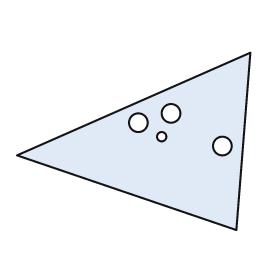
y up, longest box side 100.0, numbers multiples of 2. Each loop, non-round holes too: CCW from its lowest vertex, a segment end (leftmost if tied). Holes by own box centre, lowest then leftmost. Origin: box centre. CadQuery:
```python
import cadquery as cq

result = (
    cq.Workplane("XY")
    .moveTo(44.0, -38.0)
    .lineTo(50.0, 38.0)
    .lineTo(-50.0, -6.0)
    .close()
    .moveTo(38.0, -2.0)
    .circle(4.0)
    .moveTo(12.0, 2.0)
    .circle(2.0)
    .moveTo(2.0, 8.0)
    .circle(4.0)
    .moveTo(16.0, 12.0)
    .circle(4.0)
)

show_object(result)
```